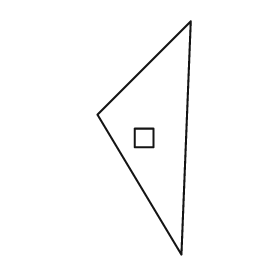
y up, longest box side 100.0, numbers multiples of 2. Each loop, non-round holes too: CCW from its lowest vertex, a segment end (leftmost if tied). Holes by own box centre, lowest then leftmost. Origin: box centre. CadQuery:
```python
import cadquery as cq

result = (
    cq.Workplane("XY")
    .moveTo(16.0, -50.0)
    .lineTo(20.0, 50.0)
    .lineTo(-20.0, 10.0)
    .close()
    .moveTo(-4.0, -4.0)
    .lineTo(4.0, -4.0)
    .lineTo(4.0, 4.0)
    .lineTo(-4.0, 4.0)
    .close()
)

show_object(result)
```